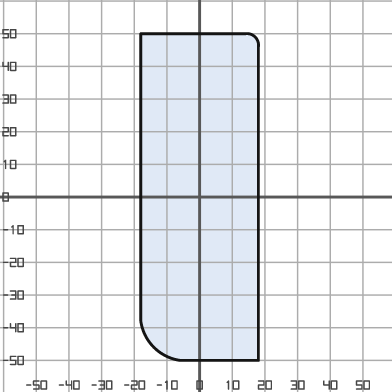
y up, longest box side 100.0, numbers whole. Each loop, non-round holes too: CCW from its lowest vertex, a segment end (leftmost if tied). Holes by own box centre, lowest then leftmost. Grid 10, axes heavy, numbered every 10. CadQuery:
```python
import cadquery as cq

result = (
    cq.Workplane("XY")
    .moveTo(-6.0, -50.0)
    .lineTo(18.0, -50.0)
    .lineTo(18.0, 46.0)
    .threePointArc((17.0, 49.0), (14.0, 50.0))
    .lineTo(-18.0, 50.0)
    .lineTo(-18.0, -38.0)
    .threePointArc((-14.0, -46.0), (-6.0, -50.0))
    .close()
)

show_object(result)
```